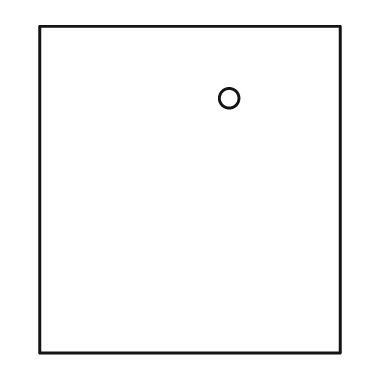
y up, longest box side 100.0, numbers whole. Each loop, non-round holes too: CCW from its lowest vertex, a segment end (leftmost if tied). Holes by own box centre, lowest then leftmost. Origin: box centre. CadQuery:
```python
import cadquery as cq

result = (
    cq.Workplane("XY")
    .moveTo(-46.0, -50.0)
    .lineTo(46.0, -50.0)
    .lineTo(46.0, 50.0)
    .lineTo(-46.0, 50.0)
    .close()
    .moveTo(12.0, 28.0)
    .circle(3.0)
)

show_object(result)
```